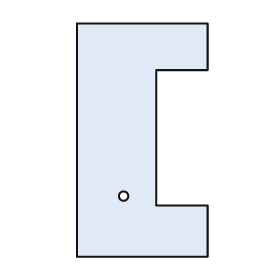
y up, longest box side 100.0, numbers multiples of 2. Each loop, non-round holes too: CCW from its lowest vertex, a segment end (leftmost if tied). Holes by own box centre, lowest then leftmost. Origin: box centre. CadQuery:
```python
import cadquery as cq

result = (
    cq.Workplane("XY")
    .moveTo(-28.0, -50.0)
    .lineTo(28.0, -50.0)
    .lineTo(28.0, -28.0)
    .lineTo(6.0, -28.0)
    .lineTo(6.0, 30.0)
    .lineTo(28.0, 30.0)
    .lineTo(28.0, 50.0)
    .lineTo(-28.0, 50.0)
    .close()
    .moveTo(-8.0, -24.0)
    .circle(2.0)
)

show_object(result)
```